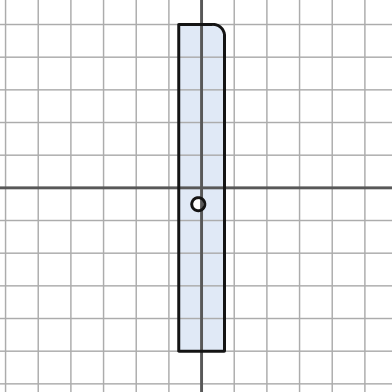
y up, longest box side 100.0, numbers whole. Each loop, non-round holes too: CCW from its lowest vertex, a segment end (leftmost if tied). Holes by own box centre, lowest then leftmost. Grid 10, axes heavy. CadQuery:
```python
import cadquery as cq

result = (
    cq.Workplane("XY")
    .moveTo(-7.0, -50.0)
    .lineTo(7.0, -50.0)
    .lineTo(7.0, 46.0)
    .threePointArc((6.0, 49.0), (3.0, 50.0))
    .lineTo(-7.0, 50.0)
    .close()
    .moveTo(-1.0, -5.0)
    .circle(2.0)
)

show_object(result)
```